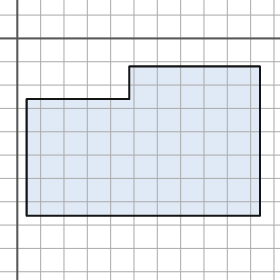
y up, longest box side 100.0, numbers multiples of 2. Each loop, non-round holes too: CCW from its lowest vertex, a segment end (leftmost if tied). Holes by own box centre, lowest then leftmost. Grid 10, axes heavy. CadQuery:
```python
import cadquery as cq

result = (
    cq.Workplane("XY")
    .moveTo(4.0, -76.0)
    .lineTo(104.0, -76.0)
    .lineTo(104.0, -12.0)
    .lineTo(48.0, -12.0)
    .lineTo(48.0, -26.0)
    .lineTo(4.0, -26.0)
    .close()
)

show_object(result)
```